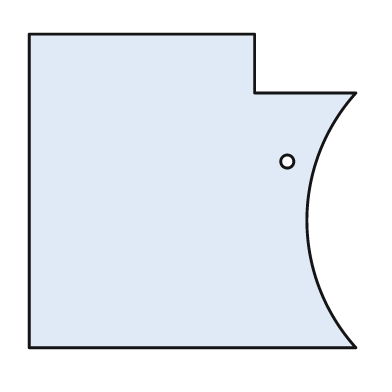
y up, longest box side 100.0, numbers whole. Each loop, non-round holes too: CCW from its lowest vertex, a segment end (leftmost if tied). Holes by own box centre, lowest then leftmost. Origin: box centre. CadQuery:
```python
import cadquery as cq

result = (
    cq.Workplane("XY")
    .moveTo(-50.0, -48.0)
    .lineTo(50.0, -48.0)
    .threePointArc((35.0, -9.0), (50.0, 30.0))
    .lineTo(19.0, 30.0)
    .lineTo(19.0, 48.0)
    .lineTo(-50.0, 48.0)
    .close()
    .moveTo(29.0, 9.0)
    .circle(2.0)
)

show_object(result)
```